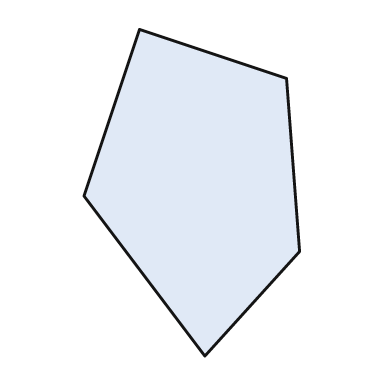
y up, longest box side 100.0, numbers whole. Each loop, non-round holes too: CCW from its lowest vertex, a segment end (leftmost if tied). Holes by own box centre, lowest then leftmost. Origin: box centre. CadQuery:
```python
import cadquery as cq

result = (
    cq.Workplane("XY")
    .moveTo(4.0, -50.0)
    .lineTo(33.0, -18.0)
    .lineTo(29.0, 35.0)
    .lineTo(-16.0, 50.0)
    .lineTo(-33.0, -1.0)
    .close()
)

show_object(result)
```